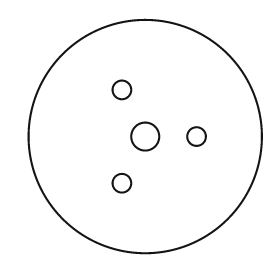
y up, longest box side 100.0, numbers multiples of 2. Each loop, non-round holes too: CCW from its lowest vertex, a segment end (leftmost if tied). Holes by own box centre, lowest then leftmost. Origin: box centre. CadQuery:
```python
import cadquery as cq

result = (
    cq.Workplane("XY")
    .moveTo(0.0, 0.0)
    .circle(50.0)
    .moveTo(-10.0, -20.0)
    .circle(4.0)
    .moveTo(0.0, 0.0)
    .circle(6.0)
    .moveTo(22.0, 0.0)
    .circle(4.0)
    .moveTo(-10.0, 20.0)
    .circle(4.0)
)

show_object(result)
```